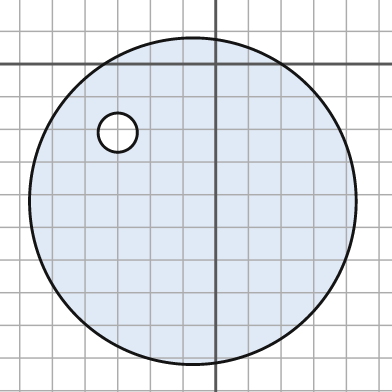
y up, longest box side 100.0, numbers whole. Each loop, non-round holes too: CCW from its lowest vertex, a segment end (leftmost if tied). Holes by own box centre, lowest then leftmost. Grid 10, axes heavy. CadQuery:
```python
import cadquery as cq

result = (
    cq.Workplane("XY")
    .moveTo(-7.0, -42.0)
    .circle(50.0)
    .moveTo(-30.0, -21.0)
    .circle(6.0)
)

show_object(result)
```